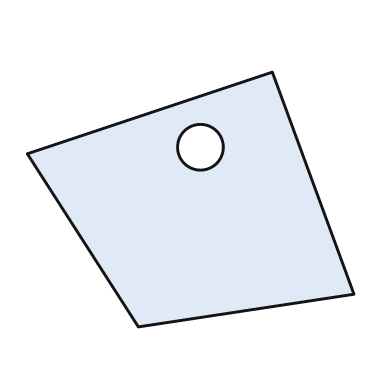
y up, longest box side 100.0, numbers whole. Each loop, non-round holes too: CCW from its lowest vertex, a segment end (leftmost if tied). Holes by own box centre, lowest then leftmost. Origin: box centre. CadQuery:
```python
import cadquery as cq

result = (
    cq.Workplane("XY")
    .moveTo(-16.0, -39.0)
    .lineTo(50.0, -29.0)
    .lineTo(25.0, 39.0)
    .lineTo(-50.0, 14.0)
    .close()
    .moveTo(3.0, 16.0)
    .circle(7.0)
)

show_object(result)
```